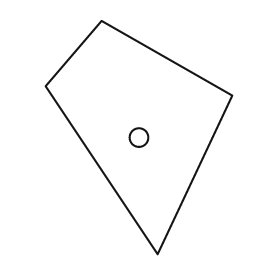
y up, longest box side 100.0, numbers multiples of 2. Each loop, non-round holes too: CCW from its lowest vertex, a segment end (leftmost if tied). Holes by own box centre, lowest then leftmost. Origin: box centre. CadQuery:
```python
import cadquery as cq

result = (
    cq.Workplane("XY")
    .moveTo(8.0, -50.0)
    .lineTo(40.0, 18.0)
    .lineTo(-16.0, 50.0)
    .lineTo(-40.0, 22.0)
    .close()
    .moveTo(0.0, 0.0)
    .circle(4.0)
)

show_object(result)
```